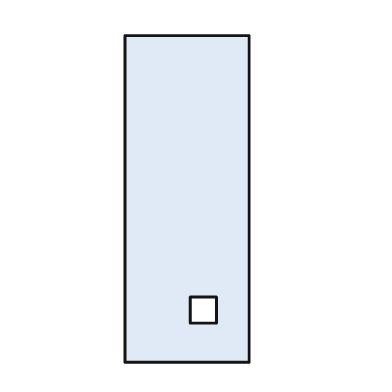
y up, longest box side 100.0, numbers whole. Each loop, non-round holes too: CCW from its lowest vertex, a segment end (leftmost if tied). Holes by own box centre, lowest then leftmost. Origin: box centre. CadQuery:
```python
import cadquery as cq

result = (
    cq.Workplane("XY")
    .moveTo(-19.0, -50.0)
    .lineTo(19.0, -50.0)
    .lineTo(19.0, 50.0)
    .lineTo(-19.0, 50.0)
    .close()
    .moveTo(1.0, -38.0)
    .lineTo(9.0, -38.0)
    .lineTo(9.0, -30.0)
    .lineTo(1.0, -30.0)
    .close()
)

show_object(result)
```